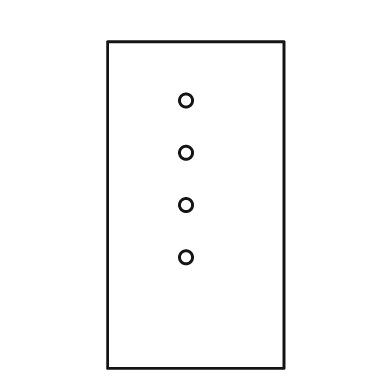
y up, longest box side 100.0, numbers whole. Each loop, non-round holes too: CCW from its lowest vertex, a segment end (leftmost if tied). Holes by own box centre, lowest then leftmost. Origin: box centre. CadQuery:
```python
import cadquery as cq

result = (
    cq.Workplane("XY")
    .moveTo(-27.0, -50.0)
    .lineTo(27.0, -50.0)
    .lineTo(27.0, 50.0)
    .lineTo(-27.0, 50.0)
    .close()
    .moveTo(-3.0, -16.0)
    .circle(2.0)
    .moveTo(-3.0, 0.0)
    .circle(2.0)
    .moveTo(-3.0, 16.0)
    .circle(2.0)
    .moveTo(-3.0, 32.0)
    .circle(2.0)
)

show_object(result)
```